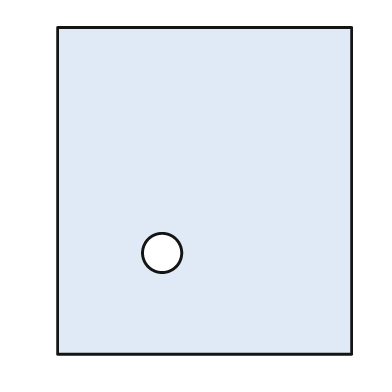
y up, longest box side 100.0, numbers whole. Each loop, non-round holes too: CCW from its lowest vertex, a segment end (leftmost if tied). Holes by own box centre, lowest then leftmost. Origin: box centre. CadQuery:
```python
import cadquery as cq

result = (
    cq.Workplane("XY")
    .moveTo(-45.0, -50.0)
    .lineTo(45.0, -50.0)
    .lineTo(45.0, 50.0)
    .lineTo(-45.0, 50.0)
    .close()
    .moveTo(-13.0, -19.0)
    .circle(6.0)
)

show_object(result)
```